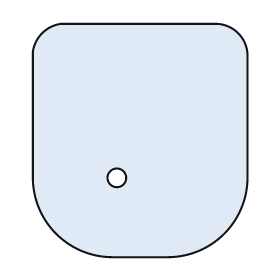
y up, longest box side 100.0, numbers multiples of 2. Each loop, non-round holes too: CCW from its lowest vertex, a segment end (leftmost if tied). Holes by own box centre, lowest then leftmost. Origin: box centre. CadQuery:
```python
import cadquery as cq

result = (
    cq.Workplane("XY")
    .moveTo(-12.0, -50.0)
    .lineTo(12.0, -50.0)
    .threePointArc((36.0, -40.0), (46.0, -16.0))
    .lineTo(46.0, 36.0)
    .threePointArc((42.0, 46.0), (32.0, 50.0))
    .lineTo(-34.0, 50.0)
    .threePointArc((-42.0, 46.0), (-46.0, 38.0))
    .lineTo(-46.0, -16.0)
    .threePointArc((-36.0, -40.0), (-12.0, -50.0))
    .close()
    .moveTo(-10.0, -16.0)
    .circle(4.0)
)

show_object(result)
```